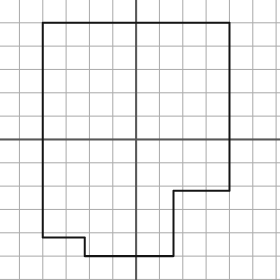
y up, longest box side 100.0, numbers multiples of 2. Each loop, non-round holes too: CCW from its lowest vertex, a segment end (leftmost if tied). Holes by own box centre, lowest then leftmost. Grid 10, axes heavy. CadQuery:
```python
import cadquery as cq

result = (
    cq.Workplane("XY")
    .moveTo(-22.0, -50.0)
    .lineTo(16.0, -50.0)
    .lineTo(16.0, -22.0)
    .lineTo(40.0, -22.0)
    .lineTo(40.0, 50.0)
    .lineTo(-40.0, 50.0)
    .lineTo(-40.0, -42.0)
    .lineTo(-22.0, -42.0)
    .close()
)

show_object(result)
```